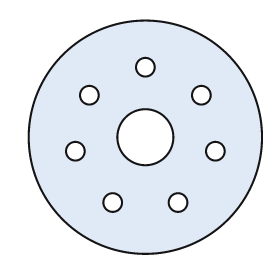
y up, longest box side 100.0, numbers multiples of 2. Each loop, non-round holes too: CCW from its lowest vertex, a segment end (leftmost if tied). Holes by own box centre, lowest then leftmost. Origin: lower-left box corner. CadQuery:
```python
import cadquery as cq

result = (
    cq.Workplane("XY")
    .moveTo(50.0, 50.0)
    .circle(50.0)
    .moveTo(36.0, 22.0)
    .circle(4.0)
    .moveTo(64.0, 22.0)
    .circle(4.0)
    .moveTo(20.0, 44.0)
    .circle(4.0)
    .moveTo(80.0, 44.0)
    .circle(4.0)
    .moveTo(50.0, 50.0)
    .circle(12.0)
    .moveTo(26.0, 68.0)
    .circle(4.0)
    .moveTo(74.0, 68.0)
    .circle(4.0)
    .moveTo(50.0, 80.0)
    .circle(4.0)
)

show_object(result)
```